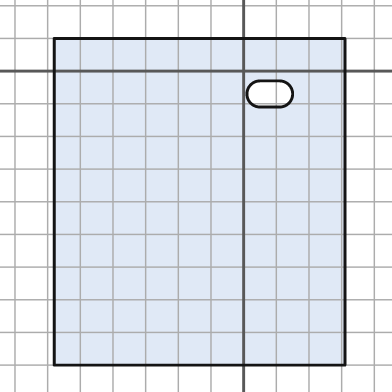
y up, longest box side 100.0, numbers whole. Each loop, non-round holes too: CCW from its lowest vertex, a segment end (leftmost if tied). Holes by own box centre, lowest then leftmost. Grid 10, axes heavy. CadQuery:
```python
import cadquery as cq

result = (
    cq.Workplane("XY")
    .moveTo(-58.0, -90.0)
    .lineTo(31.0, -90.0)
    .lineTo(31.0, 10.0)
    .lineTo(-58.0, 10.0)
    .close()
    .moveTo(5.0, -11.0)
    .lineTo(11.0, -11.0)
    .threePointArc((15.0, -7.0), (11.0, -3.0))
    .lineTo(5.0, -3.0)
    .threePointArc((1.0, -7.0), (5.0, -11.0))
    .close()
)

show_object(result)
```